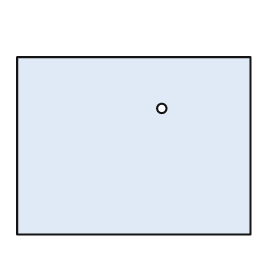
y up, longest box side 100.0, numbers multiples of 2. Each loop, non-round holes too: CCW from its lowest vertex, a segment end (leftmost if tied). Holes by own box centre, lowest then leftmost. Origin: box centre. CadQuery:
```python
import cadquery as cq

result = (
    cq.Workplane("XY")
    .moveTo(-50.0, -38.0)
    .lineTo(50.0, -38.0)
    .lineTo(50.0, 38.0)
    .lineTo(-50.0, 38.0)
    .close()
    .moveTo(12.0, 16.0)
    .circle(2.0)
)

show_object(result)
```